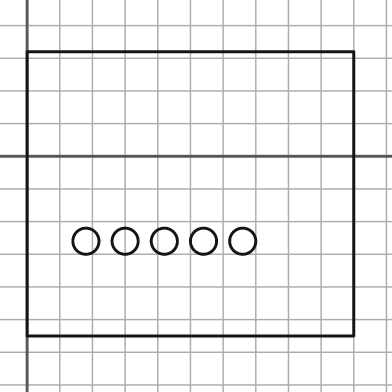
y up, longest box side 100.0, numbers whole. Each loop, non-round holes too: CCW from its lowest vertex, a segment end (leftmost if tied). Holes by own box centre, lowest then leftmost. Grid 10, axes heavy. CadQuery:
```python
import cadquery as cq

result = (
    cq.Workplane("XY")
    .moveTo(0.0, -55.0)
    .lineTo(100.0, -55.0)
    .lineTo(100.0, 32.0)
    .lineTo(0.0, 32.0)
    .close()
    .moveTo(18.0, -26.0)
    .circle(4.0)
    .moveTo(30.0, -26.0)
    .circle(4.0)
    .moveTo(42.0, -26.0)
    .circle(4.0)
    .moveTo(54.0, -26.0)
    .circle(4.0)
    .moveTo(66.0, -26.0)
    .circle(4.0)
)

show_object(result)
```